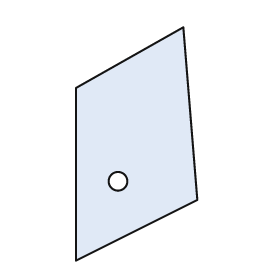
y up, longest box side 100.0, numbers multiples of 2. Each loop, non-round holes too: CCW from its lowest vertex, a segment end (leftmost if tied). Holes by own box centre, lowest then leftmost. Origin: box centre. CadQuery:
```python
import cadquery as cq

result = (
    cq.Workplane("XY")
    .moveTo(-26.0, -50.0)
    .lineTo(26.0, -24.0)
    .lineTo(20.0, 50.0)
    .lineTo(-26.0, 24.0)
    .close()
    .moveTo(-8.0, -16.0)
    .circle(4.0)
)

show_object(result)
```